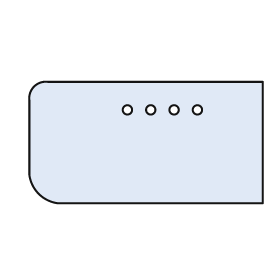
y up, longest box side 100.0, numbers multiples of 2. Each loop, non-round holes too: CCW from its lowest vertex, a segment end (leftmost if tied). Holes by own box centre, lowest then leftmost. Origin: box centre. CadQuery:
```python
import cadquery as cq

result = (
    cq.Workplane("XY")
    .moveTo(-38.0, -26.0)
    .lineTo(50.0, -26.0)
    .lineTo(50.0, 26.0)
    .lineTo(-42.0, 26.0)
    .threePointArc((-48.0, 24.0), (-50.0, 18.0))
    .lineTo(-50.0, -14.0)
    .threePointArc((-46.0, -22.0), (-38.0, -26.0))
    .close()
    .moveTo(-8.0, 14.0)
    .circle(2.0)
    .moveTo(2.0, 14.0)
    .circle(2.0)
    .moveTo(12.0, 14.0)
    .circle(2.0)
    .moveTo(22.0, 14.0)
    .circle(2.0)
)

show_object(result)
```